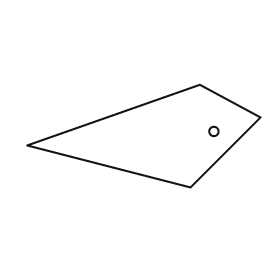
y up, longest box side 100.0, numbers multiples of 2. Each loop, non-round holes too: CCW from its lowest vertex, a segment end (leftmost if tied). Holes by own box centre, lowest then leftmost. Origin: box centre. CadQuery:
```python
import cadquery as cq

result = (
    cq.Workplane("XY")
    .moveTo(20.0, -22.0)
    .lineTo(50.0, 8.0)
    .lineTo(24.0, 22.0)
    .lineTo(-50.0, -4.0)
    .close()
    .moveTo(30.0, 2.0)
    .circle(2.0)
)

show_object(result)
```